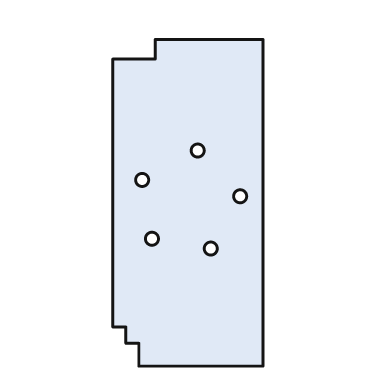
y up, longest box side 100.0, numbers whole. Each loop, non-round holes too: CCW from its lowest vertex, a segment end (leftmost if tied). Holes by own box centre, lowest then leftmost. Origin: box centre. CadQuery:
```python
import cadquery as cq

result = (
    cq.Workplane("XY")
    .moveTo(-15.0, -50.0)
    .lineTo(23.0, -50.0)
    .lineTo(23.0, 50.0)
    .lineTo(-10.0, 50.0)
    .lineTo(-10.0, 44.0)
    .lineTo(-23.0, 44.0)
    .lineTo(-23.0, -38.0)
    .lineTo(-19.0, -38.0)
    .lineTo(-19.0, -43.0)
    .lineTo(-15.0, -43.0)
    .close()
    .moveTo(7.0, -14.0)
    .circle(2.0)
    .moveTo(-11.0, -11.0)
    .circle(2.0)
    .moveTo(16.0, 2.0)
    .circle(2.0)
    .moveTo(-14.0, 7.0)
    .circle(2.0)
    .moveTo(3.0, 16.0)
    .circle(2.0)
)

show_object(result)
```